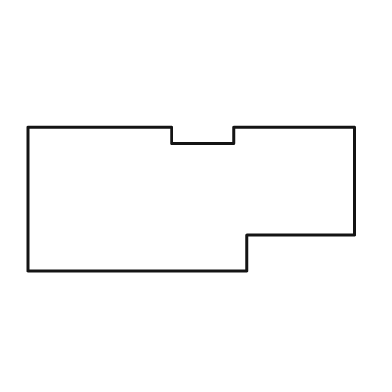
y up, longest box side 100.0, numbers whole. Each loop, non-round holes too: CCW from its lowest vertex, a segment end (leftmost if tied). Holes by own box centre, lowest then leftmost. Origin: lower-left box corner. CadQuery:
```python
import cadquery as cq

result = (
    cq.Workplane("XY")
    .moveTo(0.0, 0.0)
    .lineTo(67.0, 0.0)
    .lineTo(67.0, 11.0)
    .lineTo(100.0, 11.0)
    .lineTo(100.0, 44.0)
    .lineTo(63.0, 44.0)
    .lineTo(63.0, 39.0)
    .lineTo(44.0, 39.0)
    .lineTo(44.0, 44.0)
    .lineTo(0.0, 44.0)
    .close()
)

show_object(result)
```